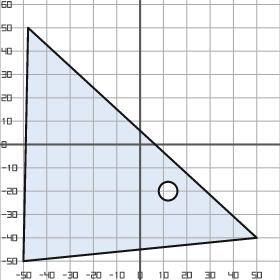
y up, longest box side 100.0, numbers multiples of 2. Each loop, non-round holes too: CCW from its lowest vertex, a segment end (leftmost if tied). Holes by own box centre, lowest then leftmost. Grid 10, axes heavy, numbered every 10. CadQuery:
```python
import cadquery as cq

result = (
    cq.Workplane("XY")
    .moveTo(-50.0, -50.0)
    .lineTo(50.0, -40.0)
    .lineTo(-48.0, 50.0)
    .close()
    .moveTo(12.0, -20.0)
    .circle(4.0)
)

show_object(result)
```